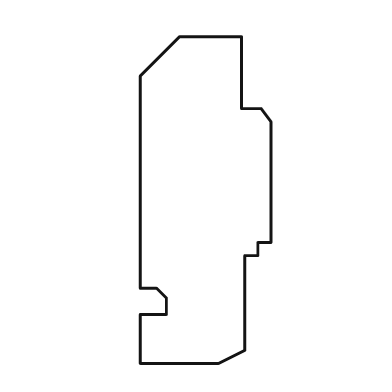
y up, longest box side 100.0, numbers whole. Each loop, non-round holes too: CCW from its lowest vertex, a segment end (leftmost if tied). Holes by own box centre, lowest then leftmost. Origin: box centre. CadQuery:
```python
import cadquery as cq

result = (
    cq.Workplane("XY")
    .moveTo(-20.0, -50.0)
    .lineTo(4.0, -50.0)
    .lineTo(12.0, -46.0)
    .lineTo(12.0, -17.0)
    .lineTo(16.0, -17.0)
    .lineTo(16.0, -13.0)
    .lineTo(20.0, -13.0)
    .lineTo(20.0, 24.0)
    .lineTo(17.0, 28.0)
    .lineTo(11.0, 28.0)
    .lineTo(11.0, 50.0)
    .lineTo(-8.0, 50.0)
    .lineTo(-20.0, 38.0)
    .lineTo(-20.0, -27.0)
    .lineTo(-15.0, -27.0)
    .lineTo(-12.0, -30.0)
    .lineTo(-12.0, -35.0)
    .lineTo(-20.0, -35.0)
    .close()
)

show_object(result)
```